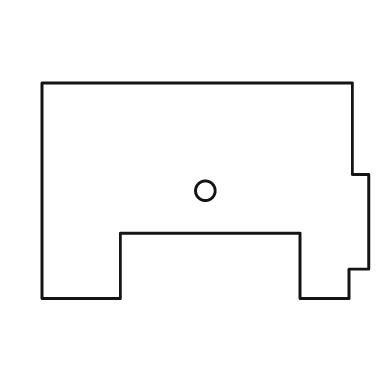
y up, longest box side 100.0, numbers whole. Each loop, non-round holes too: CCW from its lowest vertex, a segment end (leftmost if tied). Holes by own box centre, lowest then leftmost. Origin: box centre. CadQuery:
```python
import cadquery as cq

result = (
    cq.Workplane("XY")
    .moveTo(-50.0, -33.0)
    .lineTo(-26.0, -33.0)
    .lineTo(-26.0, -13.0)
    .lineTo(29.0, -13.0)
    .lineTo(29.0, -33.0)
    .lineTo(44.0, -33.0)
    .lineTo(44.0, -24.0)
    .lineTo(50.0, -24.0)
    .lineTo(50.0, 5.0)
    .lineTo(45.0, 5.0)
    .lineTo(45.0, 33.0)
    .lineTo(-50.0, 33.0)
    .close()
    .moveTo(0.0, 0.0)
    .circle(3.0)
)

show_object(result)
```